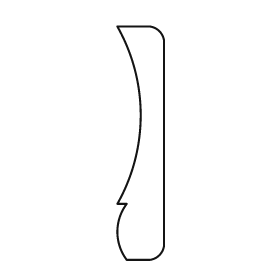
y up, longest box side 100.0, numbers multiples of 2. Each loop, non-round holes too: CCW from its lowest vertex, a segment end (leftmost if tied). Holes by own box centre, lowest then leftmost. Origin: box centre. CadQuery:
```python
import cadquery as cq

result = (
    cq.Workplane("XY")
    .moveTo(-6.0, -50.0)
    .lineTo(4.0, -50.0)
    .threePointArc((8.0, -48.0), (10.0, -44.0))
    .lineTo(10.0, 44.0)
    .threePointArc((8.0, 48.0), (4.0, 50.0))
    .lineTo(-10.0, 50.0)
    .threePointArc((0.0, 12.0), (-10.0, -26.0))
    .lineTo(-6.0, -26.0)
    .threePointArc((-10.0, -38.0), (-6.0, -50.0))
    .close()
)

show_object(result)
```